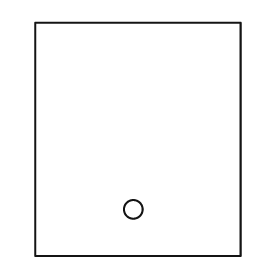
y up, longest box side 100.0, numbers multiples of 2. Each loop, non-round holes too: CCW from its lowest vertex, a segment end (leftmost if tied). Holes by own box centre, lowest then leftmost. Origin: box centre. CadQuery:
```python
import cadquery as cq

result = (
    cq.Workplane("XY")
    .moveTo(-44.0, -50.0)
    .lineTo(44.0, -50.0)
    .lineTo(44.0, 50.0)
    .lineTo(-44.0, 50.0)
    .close()
    .moveTo(-2.0, -30.0)
    .circle(4.0)
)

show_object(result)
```